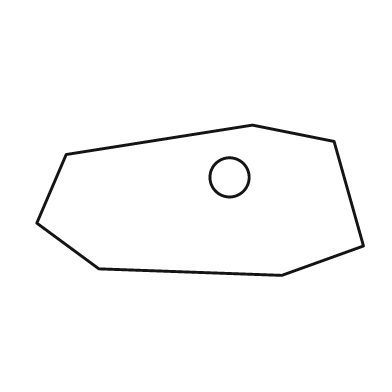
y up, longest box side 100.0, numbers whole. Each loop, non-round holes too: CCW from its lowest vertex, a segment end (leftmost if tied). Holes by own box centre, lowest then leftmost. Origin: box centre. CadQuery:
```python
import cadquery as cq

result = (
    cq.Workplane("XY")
    .moveTo(25.0, -23.0)
    .lineTo(50.0, -14.0)
    .lineTo(41.0, 18.0)
    .lineTo(16.0, 23.0)
    .lineTo(-41.0, 14.0)
    .lineTo(-50.0, -7.0)
    .lineTo(-31.0, -21.0)
    .close()
    .moveTo(9.0, 7.0)
    .circle(6.0)
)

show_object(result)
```